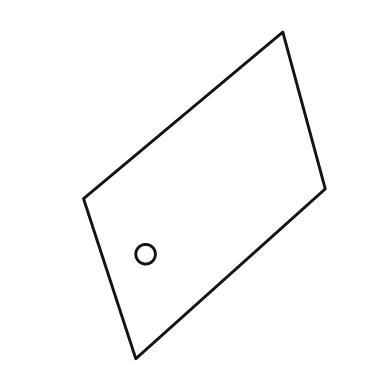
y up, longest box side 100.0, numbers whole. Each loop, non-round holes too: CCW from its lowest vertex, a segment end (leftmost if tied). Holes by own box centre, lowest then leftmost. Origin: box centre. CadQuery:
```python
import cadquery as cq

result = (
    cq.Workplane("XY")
    .moveTo(-21.0, -50.0)
    .lineTo(37.0, 2.0)
    .lineTo(24.0, 50.0)
    .lineTo(-37.0, -1.0)
    .close()
    .moveTo(-18.0, -18.0)
    .circle(3.0)
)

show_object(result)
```